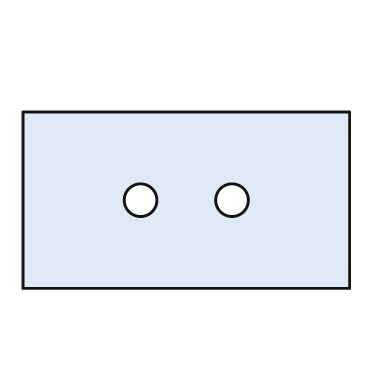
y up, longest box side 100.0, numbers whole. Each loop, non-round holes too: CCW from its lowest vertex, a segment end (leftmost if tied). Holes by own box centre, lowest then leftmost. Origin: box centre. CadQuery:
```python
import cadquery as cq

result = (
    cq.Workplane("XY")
    .moveTo(-50.0, -27.0)
    .lineTo(50.0, -27.0)
    .lineTo(50.0, 27.0)
    .lineTo(-50.0, 27.0)
    .close()
    .moveTo(-14.0, 0.0)
    .circle(5.0)
    .moveTo(14.0, 0.0)
    .circle(5.0)
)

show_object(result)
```